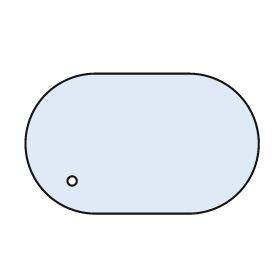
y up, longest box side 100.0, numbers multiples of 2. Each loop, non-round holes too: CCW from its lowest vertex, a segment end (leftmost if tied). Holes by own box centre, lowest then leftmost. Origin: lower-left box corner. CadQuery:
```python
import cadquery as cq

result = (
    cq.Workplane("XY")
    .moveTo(30.0, 0.0)
    .lineTo(70.0, 0.0)
    .threePointArc((100.0, 30.0), (70.0, 60.0))
    .lineTo(30.0, 60.0)
    .threePointArc((0.0, 30.0), (30.0, 0.0))
    .close()
    .moveTo(20.0, 14.0)
    .circle(2.0)
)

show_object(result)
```